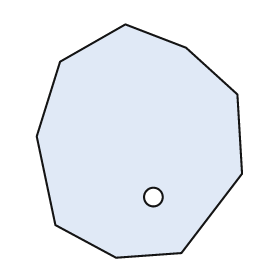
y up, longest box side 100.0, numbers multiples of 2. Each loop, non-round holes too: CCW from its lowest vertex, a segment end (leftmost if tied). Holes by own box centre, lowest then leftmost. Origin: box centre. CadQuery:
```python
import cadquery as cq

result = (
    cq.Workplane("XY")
    .moveTo(-10.0, -50.0)
    .lineTo(18.0, -48.0)
    .lineTo(44.0, -14.0)
    .lineTo(42.0, 20.0)
    .lineTo(20.0, 40.0)
    .lineTo(-6.0, 50.0)
    .lineTo(-34.0, 34.0)
    .lineTo(-44.0, 2.0)
    .lineTo(-36.0, -36.0)
    .close()
    .moveTo(6.0, -24.0)
    .circle(4.0)
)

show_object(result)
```